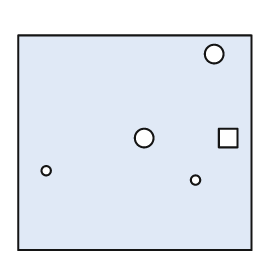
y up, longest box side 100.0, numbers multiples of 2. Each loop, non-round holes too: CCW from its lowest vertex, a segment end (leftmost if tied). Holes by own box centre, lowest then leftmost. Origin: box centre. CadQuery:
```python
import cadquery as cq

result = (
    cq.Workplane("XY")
    .moveTo(-50.0, -46.0)
    .lineTo(50.0, -46.0)
    .lineTo(50.0, 46.0)
    .lineTo(-50.0, 46.0)
    .close()
    .moveTo(26.0, -16.0)
    .circle(2.0)
    .moveTo(-38.0, -12.0)
    .circle(2.0)
    .moveTo(4.0, 2.0)
    .circle(4.0)
    .moveTo(36.0, -2.0)
    .lineTo(44.0, -2.0)
    .lineTo(44.0, 6.0)
    .lineTo(36.0, 6.0)
    .close()
    .moveTo(34.0, 38.0)
    .circle(4.0)
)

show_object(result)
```